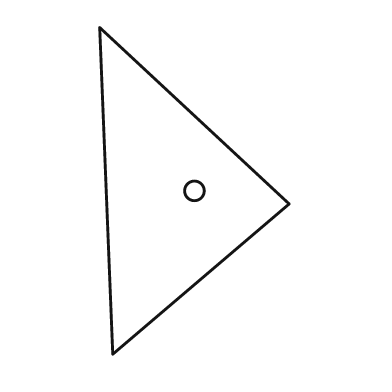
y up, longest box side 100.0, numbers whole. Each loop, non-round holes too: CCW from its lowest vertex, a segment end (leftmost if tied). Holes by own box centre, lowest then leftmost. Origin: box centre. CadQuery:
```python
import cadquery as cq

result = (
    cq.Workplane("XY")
    .moveTo(-25.0, -50.0)
    .lineTo(29.0, -4.0)
    .lineTo(-29.0, 50.0)
    .close()
    .moveTo(0.0, 0.0)
    .circle(3.0)
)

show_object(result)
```